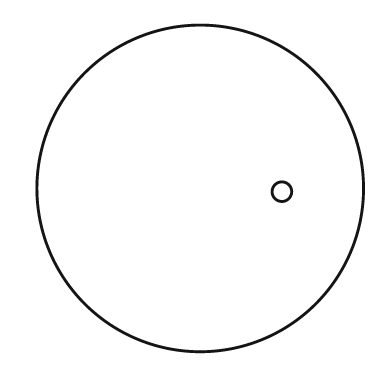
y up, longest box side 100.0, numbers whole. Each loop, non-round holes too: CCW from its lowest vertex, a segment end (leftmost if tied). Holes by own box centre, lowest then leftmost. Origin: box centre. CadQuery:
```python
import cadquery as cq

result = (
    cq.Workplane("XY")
    .moveTo(0.0, 0.0)
    .circle(50.0)
    .moveTo(25.0, -1.0)
    .circle(3.0)
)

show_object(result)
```